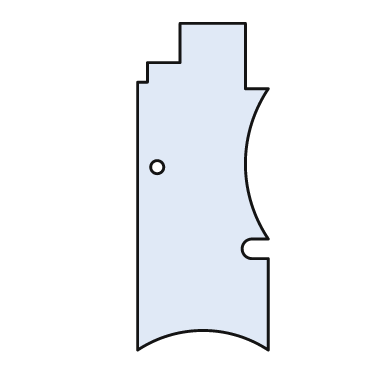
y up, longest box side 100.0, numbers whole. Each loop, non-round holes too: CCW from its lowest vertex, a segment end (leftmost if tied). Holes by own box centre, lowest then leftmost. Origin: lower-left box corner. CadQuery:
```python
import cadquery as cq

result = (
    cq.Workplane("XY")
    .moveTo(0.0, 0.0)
    .threePointArc((20.0, 6.0), (40.0, 0.0))
    .lineTo(40.0, 28.0)
    .lineTo(35.0, 28.0)
    .threePointArc((32.0, 31.0), (35.0, 34.0))
    .lineTo(40.0, 34.0)
    .threePointArc((33.0, 57.0), (40.0, 80.0))
    .lineTo(33.0, 80.0)
    .lineTo(33.0, 100.0)
    .lineTo(13.0, 100.0)
    .lineTo(13.0, 88.0)
    .lineTo(3.0, 88.0)
    .lineTo(3.0, 82.0)
    .lineTo(0.0, 82.0)
    .close()
    .moveTo(6.0, 56.0)
    .circle(2.0)
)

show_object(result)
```